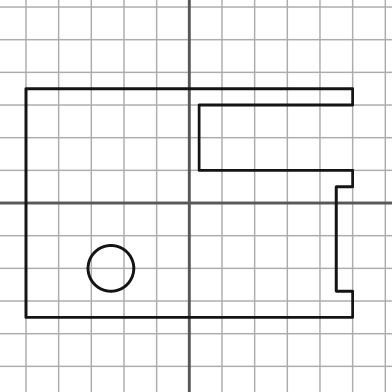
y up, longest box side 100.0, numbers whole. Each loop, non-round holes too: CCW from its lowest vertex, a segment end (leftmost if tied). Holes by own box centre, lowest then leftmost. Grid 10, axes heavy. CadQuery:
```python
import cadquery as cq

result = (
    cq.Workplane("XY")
    .moveTo(-50.0, -35.0)
    .lineTo(50.0, -35.0)
    .lineTo(50.0, -27.0)
    .lineTo(45.0, -27.0)
    .lineTo(45.0, 5.0)
    .lineTo(50.0, 5.0)
    .lineTo(50.0, 10.0)
    .lineTo(3.0, 10.0)
    .lineTo(3.0, 30.0)
    .lineTo(50.0, 30.0)
    .lineTo(50.0, 35.0)
    .lineTo(-50.0, 35.0)
    .close()
    .moveTo(-24.0, -20.0)
    .circle(7.0)
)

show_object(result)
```